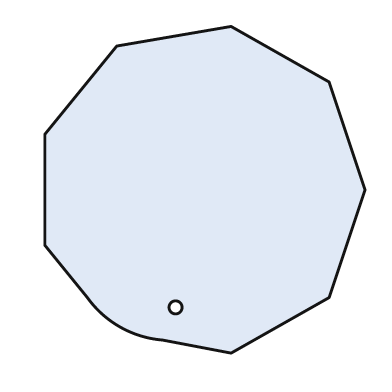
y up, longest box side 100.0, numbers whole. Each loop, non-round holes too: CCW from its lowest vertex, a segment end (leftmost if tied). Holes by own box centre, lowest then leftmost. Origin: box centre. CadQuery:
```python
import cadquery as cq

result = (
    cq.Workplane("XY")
    .moveTo(8.0, -50.0)
    .lineTo(38.0, -33.0)
    .lineTo(49.0, 0.0)
    .lineTo(38.0, 33.0)
    .lineTo(8.0, 50.0)
    .lineTo(-27.0, 44.0)
    .lineTo(-49.0, 17.0)
    .lineTo(-49.0, -17.0)
    .lineTo(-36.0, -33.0)
    .threePointArc((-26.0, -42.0), (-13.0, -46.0))
    .close()
    .moveTo(-9.0, -36.0)
    .circle(2.0)
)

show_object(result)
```